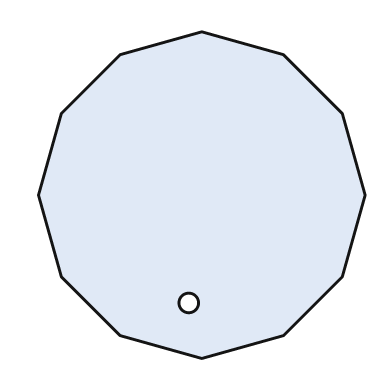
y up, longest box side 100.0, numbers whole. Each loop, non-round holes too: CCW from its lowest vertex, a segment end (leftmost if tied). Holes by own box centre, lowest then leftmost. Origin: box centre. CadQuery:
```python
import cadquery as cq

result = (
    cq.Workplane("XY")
    .moveTo(0.0, -50.0)
    .lineTo(25.0, -43.0)
    .lineTo(43.0, -25.0)
    .lineTo(50.0, 0.0)
    .lineTo(43.0, 25.0)
    .lineTo(25.0, 43.0)
    .lineTo(0.0, 50.0)
    .lineTo(-25.0, 43.0)
    .lineTo(-43.0, 25.0)
    .lineTo(-50.0, 0.0)
    .lineTo(-43.0, -25.0)
    .lineTo(-25.0, -43.0)
    .close()
    .moveTo(-4.0, -33.0)
    .circle(3.0)
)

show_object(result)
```